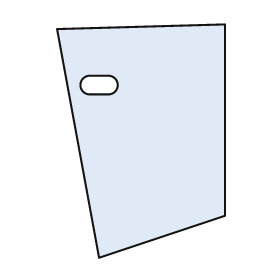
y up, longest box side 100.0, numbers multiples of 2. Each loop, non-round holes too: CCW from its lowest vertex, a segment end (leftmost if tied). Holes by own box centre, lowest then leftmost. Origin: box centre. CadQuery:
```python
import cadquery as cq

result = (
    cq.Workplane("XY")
    .moveTo(-18.0, -50.0)
    .lineTo(36.0, -32.0)
    .lineTo(36.0, 50.0)
    .lineTo(-36.0, 48.0)
    .close()
    .moveTo(-22.0, 20.0)
    .lineTo(-14.0, 20.0)
    .threePointArc((-10.0, 24.0), (-14.0, 28.0))
    .lineTo(-22.0, 28.0)
    .threePointArc((-26.0, 24.0), (-22.0, 20.0))
    .close()
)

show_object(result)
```